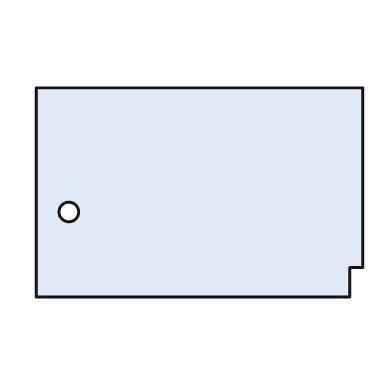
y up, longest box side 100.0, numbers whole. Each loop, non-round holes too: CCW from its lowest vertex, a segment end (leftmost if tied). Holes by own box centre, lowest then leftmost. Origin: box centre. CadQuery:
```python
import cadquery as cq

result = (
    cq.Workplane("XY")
    .moveTo(-50.0, -32.0)
    .lineTo(46.0, -32.0)
    .lineTo(46.0, -23.0)
    .lineTo(50.0, -23.0)
    .lineTo(50.0, 32.0)
    .lineTo(-50.0, 32.0)
    .close()
    .moveTo(-40.0, -6.0)
    .circle(3.0)
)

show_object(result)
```